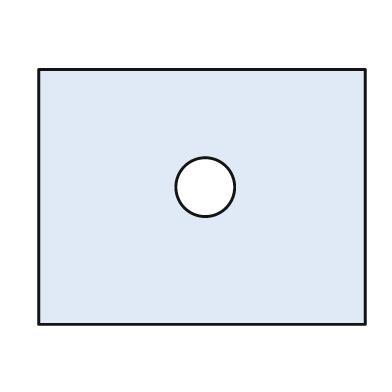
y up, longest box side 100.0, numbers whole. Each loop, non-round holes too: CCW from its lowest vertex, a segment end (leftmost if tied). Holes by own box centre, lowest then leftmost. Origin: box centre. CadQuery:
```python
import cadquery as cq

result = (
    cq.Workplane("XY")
    .moveTo(-50.0, -39.0)
    .lineTo(50.0, -39.0)
    .lineTo(50.0, 39.0)
    .lineTo(-50.0, 39.0)
    .close()
    .moveTo(1.0, 3.0)
    .circle(9.0)
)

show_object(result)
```